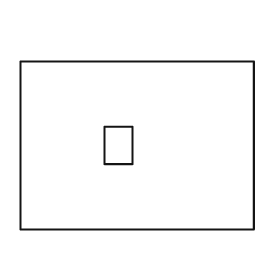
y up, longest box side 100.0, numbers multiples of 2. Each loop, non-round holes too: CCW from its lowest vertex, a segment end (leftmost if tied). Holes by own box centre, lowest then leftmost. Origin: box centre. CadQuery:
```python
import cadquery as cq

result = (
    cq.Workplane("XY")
    .moveTo(-50.0, -36.0)
    .lineTo(50.0, -36.0)
    .lineTo(50.0, 36.0)
    .lineTo(-50.0, 36.0)
    .close()
    .moveTo(-14.0, -8.0)
    .lineTo(-2.0, -8.0)
    .lineTo(-2.0, 8.0)
    .lineTo(-14.0, 8.0)
    .close()
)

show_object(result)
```